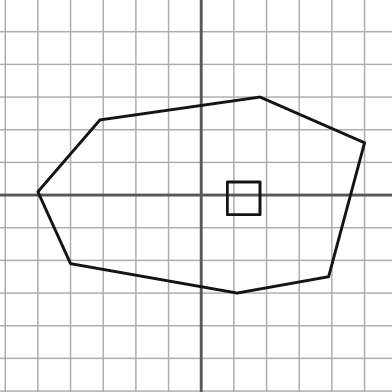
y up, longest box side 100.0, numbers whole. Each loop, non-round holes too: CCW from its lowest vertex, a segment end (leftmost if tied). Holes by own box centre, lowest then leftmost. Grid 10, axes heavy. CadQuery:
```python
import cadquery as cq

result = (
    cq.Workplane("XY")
    .moveTo(11.0, -30.0)
    .lineTo(39.0, -25.0)
    .lineTo(50.0, 16.0)
    .lineTo(18.0, 30.0)
    .lineTo(-31.0, 23.0)
    .lineTo(-50.0, 1.0)
    .lineTo(-40.0, -21.0)
    .close()
    .moveTo(8.0, -6.0)
    .lineTo(18.0, -6.0)
    .lineTo(18.0, 4.0)
    .lineTo(8.0, 4.0)
    .close()
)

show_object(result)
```